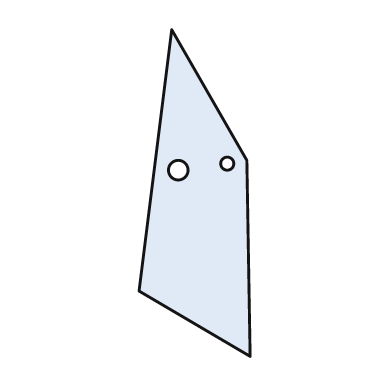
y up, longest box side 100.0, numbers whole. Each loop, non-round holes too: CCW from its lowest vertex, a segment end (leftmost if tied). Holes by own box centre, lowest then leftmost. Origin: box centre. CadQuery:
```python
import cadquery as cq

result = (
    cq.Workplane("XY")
    .moveTo(17.0, -50.0)
    .lineTo(16.0, 10.0)
    .lineTo(-7.0, 50.0)
    .lineTo(-17.0, -30.0)
    .close()
    .moveTo(-5.0, 7.0)
    .circle(3.0)
    .moveTo(10.0, 9.0)
    .circle(2.0)
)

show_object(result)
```